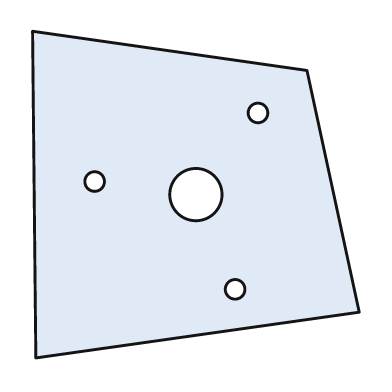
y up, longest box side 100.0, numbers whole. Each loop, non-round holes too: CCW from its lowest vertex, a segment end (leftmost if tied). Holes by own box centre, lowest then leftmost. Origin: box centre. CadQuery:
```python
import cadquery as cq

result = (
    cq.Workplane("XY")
    .moveTo(-49.0, -50.0)
    .lineTo(50.0, -36.0)
    .lineTo(34.0, 38.0)
    .lineTo(-50.0, 50.0)
    .close()
    .moveTo(12.0, -29.0)
    .circle(3.0)
    .moveTo(0.0, 0.0)
    .circle(8.0)
    .moveTo(-31.0, 4.0)
    .circle(3.0)
    .moveTo(19.0, 25.0)
    .circle(3.0)
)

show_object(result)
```